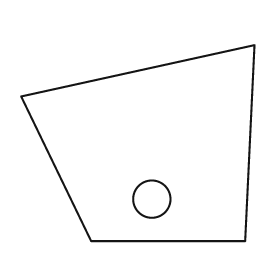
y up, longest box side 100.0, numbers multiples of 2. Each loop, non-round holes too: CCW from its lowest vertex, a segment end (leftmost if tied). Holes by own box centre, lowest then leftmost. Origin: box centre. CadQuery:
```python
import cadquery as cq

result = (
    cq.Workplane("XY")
    .moveTo(-20.0, -42.0)
    .lineTo(46.0, -42.0)
    .lineTo(50.0, 42.0)
    .lineTo(-50.0, 20.0)
    .close()
    .moveTo(6.0, -24.0)
    .circle(8.0)
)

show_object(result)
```